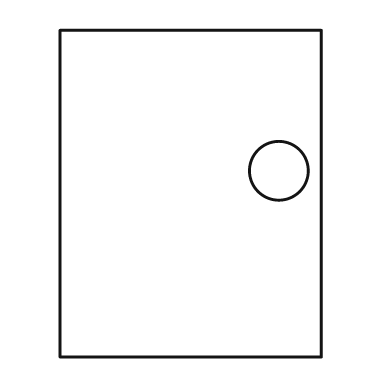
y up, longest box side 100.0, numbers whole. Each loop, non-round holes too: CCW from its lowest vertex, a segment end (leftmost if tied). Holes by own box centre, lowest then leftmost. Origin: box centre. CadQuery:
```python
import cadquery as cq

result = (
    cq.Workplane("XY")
    .moveTo(-40.0, -50.0)
    .lineTo(40.0, -50.0)
    .lineTo(40.0, 50.0)
    .lineTo(-40.0, 50.0)
    .close()
    .moveTo(27.0, 7.0)
    .circle(9.0)
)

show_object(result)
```